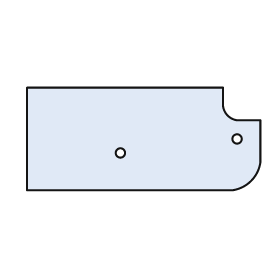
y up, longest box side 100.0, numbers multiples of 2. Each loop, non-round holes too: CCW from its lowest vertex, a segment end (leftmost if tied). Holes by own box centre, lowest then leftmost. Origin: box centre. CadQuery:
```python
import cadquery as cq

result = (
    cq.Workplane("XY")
    .moveTo(-50.0, -22.0)
    .lineTo(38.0, -22.0)
    .threePointArc((46.0, -18.0), (50.0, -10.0))
    .lineTo(50.0, 8.0)
    .lineTo(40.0, 8.0)
    .threePointArc((36.0, 10.0), (34.0, 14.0))
    .lineTo(34.0, 22.0)
    .lineTo(-50.0, 22.0)
    .close()
    .moveTo(-10.0, -6.0)
    .circle(2.0)
    .moveTo(40.0, 0.0)
    .circle(2.0)
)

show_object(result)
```